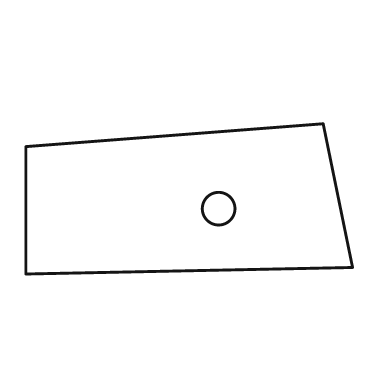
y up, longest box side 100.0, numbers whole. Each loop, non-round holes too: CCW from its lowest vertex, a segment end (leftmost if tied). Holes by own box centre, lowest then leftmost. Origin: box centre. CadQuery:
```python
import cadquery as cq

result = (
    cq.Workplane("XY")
    .moveTo(-50.0, -23.0)
    .lineTo(50.0, -21.0)
    .lineTo(41.0, 23.0)
    .lineTo(-50.0, 16.0)
    .close()
    .moveTo(9.0, -3.0)
    .circle(5.0)
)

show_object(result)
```